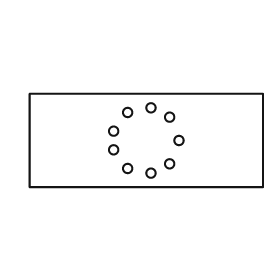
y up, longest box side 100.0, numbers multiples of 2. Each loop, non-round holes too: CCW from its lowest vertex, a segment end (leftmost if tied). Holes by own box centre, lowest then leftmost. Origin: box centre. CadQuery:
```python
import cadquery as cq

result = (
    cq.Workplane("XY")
    .moveTo(-50.0, -20.0)
    .lineTo(50.0, -20.0)
    .lineTo(50.0, 20.0)
    .lineTo(-50.0, 20.0)
    .close()
    .moveTo(2.0, -14.0)
    .circle(2.0)
    .moveTo(-8.0, -12.0)
    .circle(2.0)
    .moveTo(10.0, -10.0)
    .circle(2.0)
    .moveTo(-14.0, -4.0)
    .circle(2.0)
    .moveTo(14.0, 0.0)
    .circle(2.0)
    .moveTo(-14.0, 4.0)
    .circle(2.0)
    .moveTo(10.0, 10.0)
    .circle(2.0)
    .moveTo(-8.0, 12.0)
    .circle(2.0)
    .moveTo(2.0, 14.0)
    .circle(2.0)
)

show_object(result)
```